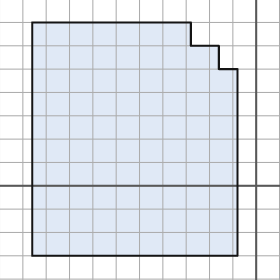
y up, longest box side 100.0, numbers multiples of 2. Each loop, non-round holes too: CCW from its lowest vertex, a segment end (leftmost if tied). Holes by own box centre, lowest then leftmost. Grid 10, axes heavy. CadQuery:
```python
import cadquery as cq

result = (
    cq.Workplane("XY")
    .moveTo(-96.0, -30.0)
    .lineTo(-8.0, -30.0)
    .lineTo(-8.0, 50.0)
    .lineTo(-16.0, 50.0)
    .lineTo(-16.0, 60.0)
    .lineTo(-28.0, 60.0)
    .lineTo(-28.0, 70.0)
    .lineTo(-96.0, 70.0)
    .close()
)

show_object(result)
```